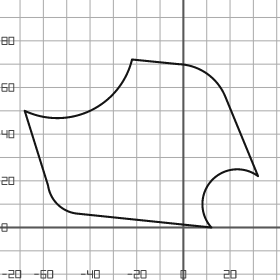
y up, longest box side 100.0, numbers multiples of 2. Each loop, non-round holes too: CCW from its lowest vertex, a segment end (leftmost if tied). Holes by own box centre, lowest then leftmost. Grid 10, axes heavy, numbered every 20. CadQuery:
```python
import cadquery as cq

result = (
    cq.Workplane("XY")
    .moveTo(12.0, 0.0)
    .threePointArc((12.0, 20.0), (32.0, 22.0))
    .lineTo(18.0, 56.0)
    .threePointArc((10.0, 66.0), (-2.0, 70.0))
    .lineTo(-22.0, 72.0)
    .threePointArc((-40.0, 50.0), (-68.0, 50.0))
    .lineTo(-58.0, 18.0)
    .threePointArc((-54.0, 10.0), (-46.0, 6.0))
    .close()
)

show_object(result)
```